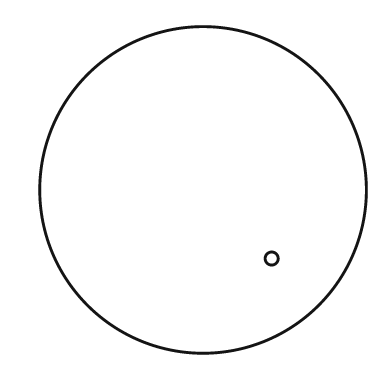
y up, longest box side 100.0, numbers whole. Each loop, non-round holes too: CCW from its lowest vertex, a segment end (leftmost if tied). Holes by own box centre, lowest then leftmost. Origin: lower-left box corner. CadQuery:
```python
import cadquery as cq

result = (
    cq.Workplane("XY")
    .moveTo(50.0, 50.0)
    .circle(50.0)
    .moveTo(71.0, 29.0)
    .circle(2.0)
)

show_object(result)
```